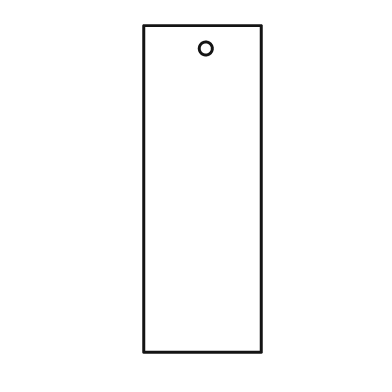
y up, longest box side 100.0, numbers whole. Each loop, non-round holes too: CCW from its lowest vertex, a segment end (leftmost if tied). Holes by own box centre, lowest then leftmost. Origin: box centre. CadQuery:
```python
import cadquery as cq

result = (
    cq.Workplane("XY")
    .moveTo(-18.0, -50.0)
    .lineTo(18.0, -50.0)
    .lineTo(18.0, 50.0)
    .lineTo(-18.0, 50.0)
    .close()
    .moveTo(1.0, 43.0)
    .circle(2.0)
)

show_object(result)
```